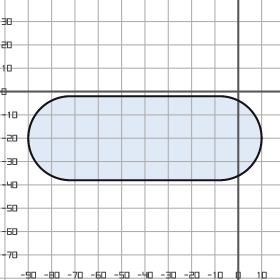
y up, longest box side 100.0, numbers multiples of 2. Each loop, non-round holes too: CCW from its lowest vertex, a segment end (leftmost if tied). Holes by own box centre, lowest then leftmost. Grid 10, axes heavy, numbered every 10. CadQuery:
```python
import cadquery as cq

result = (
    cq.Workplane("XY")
    .moveTo(-72.0, -38.0)
    .lineTo(-8.0, -38.0)
    .threePointArc((10.0, -20.0), (-8.0, -2.0))
    .lineTo(-72.0, -2.0)
    .threePointArc((-90.0, -20.0), (-72.0, -38.0))
    .close()
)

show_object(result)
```